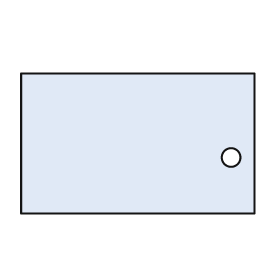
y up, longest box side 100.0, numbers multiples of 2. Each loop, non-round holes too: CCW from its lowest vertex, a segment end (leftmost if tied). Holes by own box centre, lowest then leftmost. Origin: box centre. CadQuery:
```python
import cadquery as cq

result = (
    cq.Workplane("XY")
    .moveTo(-50.0, -30.0)
    .lineTo(50.0, -30.0)
    .lineTo(50.0, 30.0)
    .lineTo(-50.0, 30.0)
    .close()
    .moveTo(40.0, -6.0)
    .circle(4.0)
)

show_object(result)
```